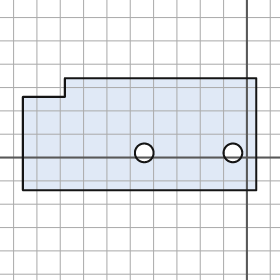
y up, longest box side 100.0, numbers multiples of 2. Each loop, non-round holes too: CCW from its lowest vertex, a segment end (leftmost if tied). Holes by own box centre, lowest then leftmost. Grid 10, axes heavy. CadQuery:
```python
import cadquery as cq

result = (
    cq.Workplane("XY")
    .moveTo(-96.0, -14.0)
    .lineTo(4.0, -14.0)
    .lineTo(4.0, 34.0)
    .lineTo(-78.0, 34.0)
    .lineTo(-78.0, 26.0)
    .lineTo(-96.0, 26.0)
    .close()
    .moveTo(-44.0, 2.0)
    .circle(4.0)
    .moveTo(-6.0, 2.0)
    .circle(4.0)
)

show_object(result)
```